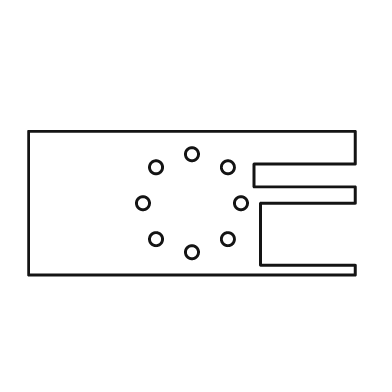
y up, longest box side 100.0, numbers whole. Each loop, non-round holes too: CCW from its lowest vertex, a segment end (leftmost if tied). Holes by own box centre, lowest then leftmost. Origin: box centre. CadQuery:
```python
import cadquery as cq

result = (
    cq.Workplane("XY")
    .moveTo(-50.0, -22.0)
    .lineTo(50.0, -22.0)
    .lineTo(50.0, -19.0)
    .lineTo(21.0, -19.0)
    .lineTo(21.0, 0.0)
    .lineTo(50.0, 0.0)
    .lineTo(50.0, 5.0)
    .lineTo(19.0, 5.0)
    .lineTo(19.0, 12.0)
    .lineTo(50.0, 12.0)
    .lineTo(50.0, 22.0)
    .lineTo(-50.0, 22.0)
    .close()
    .moveTo(0.0, -15.0)
    .circle(2.0)
    .moveTo(-11.0, -11.0)
    .circle(2.0)
    .moveTo(11.0, -11.0)
    .circle(2.0)
    .moveTo(-15.0, 0.0)
    .circle(2.0)
    .moveTo(15.0, 0.0)
    .circle(2.0)
    .moveTo(-11.0, 11.0)
    .circle(2.0)
    .moveTo(11.0, 11.0)
    .circle(2.0)
    .moveTo(0.0, 15.0)
    .circle(2.0)
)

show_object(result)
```